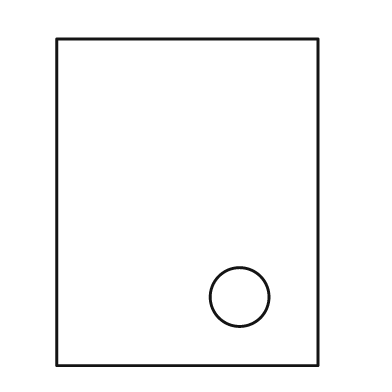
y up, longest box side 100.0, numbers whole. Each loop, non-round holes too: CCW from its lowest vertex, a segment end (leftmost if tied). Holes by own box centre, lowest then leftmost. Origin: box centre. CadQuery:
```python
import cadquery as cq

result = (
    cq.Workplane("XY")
    .moveTo(-40.0, -50.0)
    .lineTo(40.0, -50.0)
    .lineTo(40.0, 50.0)
    .lineTo(-40.0, 50.0)
    .close()
    .moveTo(16.0, -29.0)
    .circle(9.0)
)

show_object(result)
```